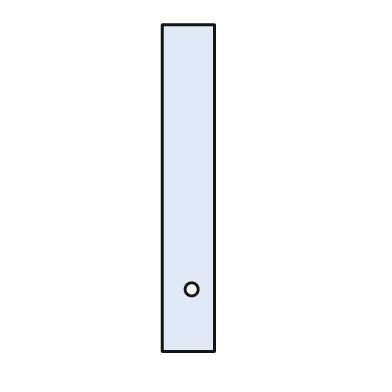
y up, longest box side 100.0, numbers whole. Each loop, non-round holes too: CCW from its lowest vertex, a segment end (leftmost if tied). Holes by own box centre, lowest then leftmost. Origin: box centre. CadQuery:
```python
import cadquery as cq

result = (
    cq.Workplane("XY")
    .moveTo(-8.0, -50.0)
    .lineTo(8.0, -50.0)
    .lineTo(8.0, 50.0)
    .lineTo(-8.0, 50.0)
    .close()
    .moveTo(1.0, -31.0)
    .circle(2.0)
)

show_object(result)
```